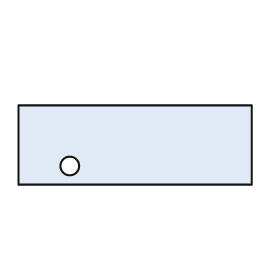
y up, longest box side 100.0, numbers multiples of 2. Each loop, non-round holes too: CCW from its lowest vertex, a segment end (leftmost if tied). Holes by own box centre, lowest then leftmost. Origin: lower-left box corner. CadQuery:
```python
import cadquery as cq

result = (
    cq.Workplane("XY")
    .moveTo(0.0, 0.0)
    .lineTo(100.0, 0.0)
    .lineTo(100.0, 34.0)
    .lineTo(0.0, 34.0)
    .close()
    .moveTo(22.0, 8.0)
    .circle(4.0)
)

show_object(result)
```